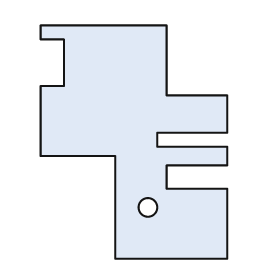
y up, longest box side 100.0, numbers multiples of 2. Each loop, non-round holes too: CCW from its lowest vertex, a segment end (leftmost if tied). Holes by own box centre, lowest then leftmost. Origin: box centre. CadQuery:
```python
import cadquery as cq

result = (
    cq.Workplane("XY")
    .moveTo(-8.0, -50.0)
    .lineTo(40.0, -50.0)
    .lineTo(40.0, -20.0)
    .lineTo(14.0, -20.0)
    .lineTo(14.0, -10.0)
    .lineTo(40.0, -10.0)
    .lineTo(40.0, -2.0)
    .lineTo(10.0, -2.0)
    .lineTo(10.0, 4.0)
    .lineTo(40.0, 4.0)
    .lineTo(40.0, 20.0)
    .lineTo(14.0, 20.0)
    .lineTo(14.0, 50.0)
    .lineTo(-40.0, 50.0)
    .lineTo(-40.0, 44.0)
    .lineTo(-30.0, 44.0)
    .lineTo(-30.0, 24.0)
    .lineTo(-40.0, 24.0)
    .lineTo(-40.0, -6.0)
    .lineTo(-8.0, -6.0)
    .close()
    .moveTo(6.0, -28.0)
    .circle(4.0)
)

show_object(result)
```